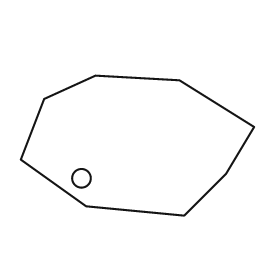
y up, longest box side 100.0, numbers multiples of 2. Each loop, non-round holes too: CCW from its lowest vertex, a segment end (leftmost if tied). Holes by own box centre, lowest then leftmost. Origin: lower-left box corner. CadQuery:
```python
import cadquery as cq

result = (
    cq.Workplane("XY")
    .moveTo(70.0, 0.0)
    .lineTo(88.0, 18.0)
    .lineTo(100.0, 38.0)
    .lineTo(68.0, 58.0)
    .lineTo(32.0, 60.0)
    .lineTo(10.0, 50.0)
    .lineTo(0.0, 24.0)
    .lineTo(28.0, 4.0)
    .close()
    .moveTo(26.0, 16.0)
    .circle(4.0)
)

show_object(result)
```